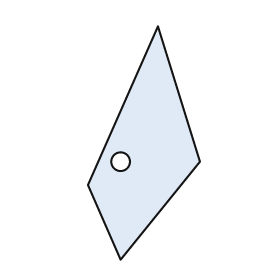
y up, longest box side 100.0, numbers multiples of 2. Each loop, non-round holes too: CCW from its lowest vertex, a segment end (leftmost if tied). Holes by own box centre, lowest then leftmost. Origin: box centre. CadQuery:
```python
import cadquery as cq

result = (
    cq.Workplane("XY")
    .moveTo(-10.0, -50.0)
    .lineTo(24.0, -8.0)
    .lineTo(6.0, 50.0)
    .lineTo(-24.0, -18.0)
    .close()
    .moveTo(-10.0, -8.0)
    .circle(4.0)
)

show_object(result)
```